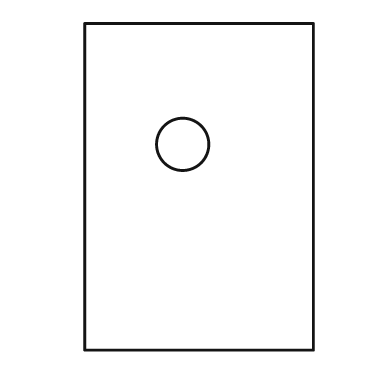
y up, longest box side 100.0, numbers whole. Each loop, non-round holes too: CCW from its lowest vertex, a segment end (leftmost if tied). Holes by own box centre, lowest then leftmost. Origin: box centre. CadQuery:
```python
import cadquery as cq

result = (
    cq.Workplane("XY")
    .moveTo(-35.0, -50.0)
    .lineTo(35.0, -50.0)
    .lineTo(35.0, 50.0)
    .lineTo(-35.0, 50.0)
    .close()
    .moveTo(-5.0, 13.0)
    .circle(8.0)
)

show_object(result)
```